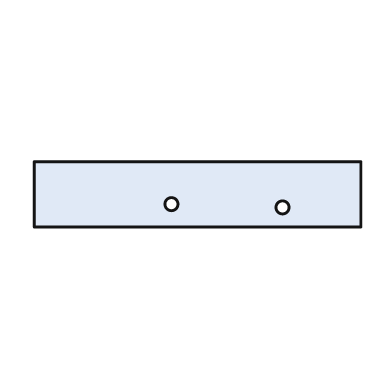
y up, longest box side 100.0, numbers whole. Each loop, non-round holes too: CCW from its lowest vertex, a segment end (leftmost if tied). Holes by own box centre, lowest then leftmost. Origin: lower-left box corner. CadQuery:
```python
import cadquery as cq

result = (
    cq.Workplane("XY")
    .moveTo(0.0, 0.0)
    .lineTo(100.0, 0.0)
    .lineTo(100.0, 20.0)
    .lineTo(0.0, 20.0)
    .close()
    .moveTo(76.0, 6.0)
    .circle(2.0)
    .moveTo(42.0, 7.0)
    .circle(2.0)
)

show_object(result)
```